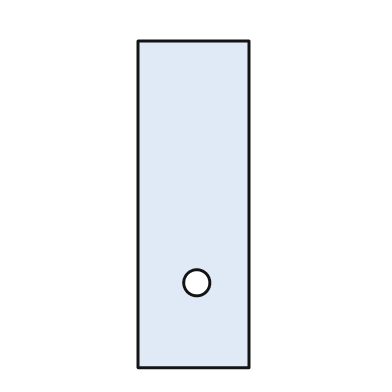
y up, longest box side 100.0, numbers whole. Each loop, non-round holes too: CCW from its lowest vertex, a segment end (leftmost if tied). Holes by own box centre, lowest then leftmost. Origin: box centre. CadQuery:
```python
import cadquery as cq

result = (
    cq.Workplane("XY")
    .moveTo(-17.0, -50.0)
    .lineTo(17.0, -50.0)
    .lineTo(17.0, 50.0)
    .lineTo(-17.0, 50.0)
    .close()
    .moveTo(1.0, -24.0)
    .circle(4.0)
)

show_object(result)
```